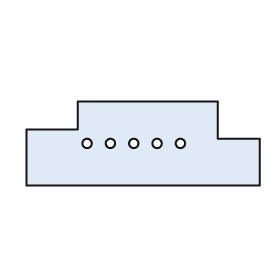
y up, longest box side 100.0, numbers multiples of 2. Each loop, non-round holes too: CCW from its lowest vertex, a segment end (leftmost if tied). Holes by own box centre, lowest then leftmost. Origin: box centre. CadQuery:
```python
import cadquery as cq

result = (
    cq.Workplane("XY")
    .moveTo(-50.0, -18.0)
    .lineTo(50.0, -18.0)
    .lineTo(50.0, 2.0)
    .lineTo(32.0, 2.0)
    .lineTo(32.0, 18.0)
    .lineTo(-28.0, 18.0)
    .lineTo(-28.0, 6.0)
    .lineTo(-50.0, 6.0)
    .close()
    .moveTo(-24.0, 0.0)
    .circle(2.0)
    .moveTo(-14.0, 0.0)
    .circle(2.0)
    .moveTo(-4.0, 0.0)
    .circle(2.0)
    .moveTo(6.0, 0.0)
    .circle(2.0)
    .moveTo(16.0, 0.0)
    .circle(2.0)
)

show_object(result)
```